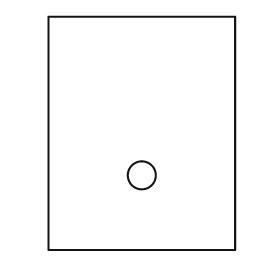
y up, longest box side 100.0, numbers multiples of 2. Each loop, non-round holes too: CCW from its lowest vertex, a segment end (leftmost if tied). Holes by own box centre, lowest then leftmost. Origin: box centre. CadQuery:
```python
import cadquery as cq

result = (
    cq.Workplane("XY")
    .moveTo(-40.0, -50.0)
    .lineTo(40.0, -50.0)
    .lineTo(40.0, 50.0)
    .lineTo(-40.0, 50.0)
    .close()
    .moveTo(0.0, -18.0)
    .circle(6.0)
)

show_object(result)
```